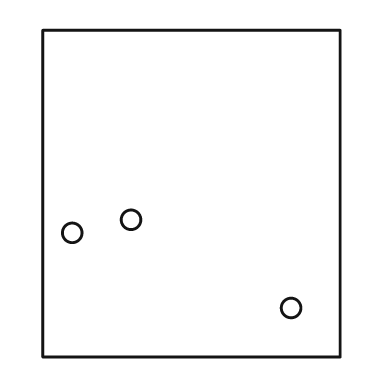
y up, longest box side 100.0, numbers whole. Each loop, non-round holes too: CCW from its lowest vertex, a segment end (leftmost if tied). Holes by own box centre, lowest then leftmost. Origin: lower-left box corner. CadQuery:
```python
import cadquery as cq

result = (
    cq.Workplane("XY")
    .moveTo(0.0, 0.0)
    .lineTo(91.0, 0.0)
    .lineTo(91.0, 100.0)
    .lineTo(0.0, 100.0)
    .close()
    .moveTo(76.0, 15.0)
    .circle(3.0)
    .moveTo(9.0, 38.0)
    .circle(3.0)
    .moveTo(27.0, 42.0)
    .circle(3.0)
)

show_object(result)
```